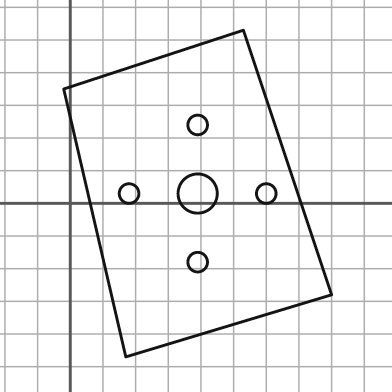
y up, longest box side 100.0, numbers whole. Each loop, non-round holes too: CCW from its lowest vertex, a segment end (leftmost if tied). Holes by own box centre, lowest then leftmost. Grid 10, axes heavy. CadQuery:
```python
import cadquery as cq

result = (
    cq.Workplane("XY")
    .moveTo(17.0, -47.0)
    .lineTo(80.0, -28.0)
    .lineTo(53.0, 53.0)
    .lineTo(-2.0, 35.0)
    .close()
    .moveTo(39.0, -18.0)
    .circle(3.0)
    .moveTo(18.0, 3.0)
    .circle(3.0)
    .moveTo(39.0, 3.0)
    .circle(6.0)
    .moveTo(60.0, 3.0)
    .circle(3.0)
    .moveTo(39.0, 24.0)
    .circle(3.0)
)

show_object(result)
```